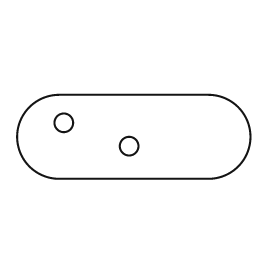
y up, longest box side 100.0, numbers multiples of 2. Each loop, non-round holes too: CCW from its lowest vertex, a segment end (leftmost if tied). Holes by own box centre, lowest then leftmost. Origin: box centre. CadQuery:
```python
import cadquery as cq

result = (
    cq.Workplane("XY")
    .moveTo(-32.0, -18.0)
    .lineTo(32.0, -18.0)
    .threePointArc((50.0, 0.0), (32.0, 18.0))
    .lineTo(-32.0, 18.0)
    .threePointArc((-50.0, 0.0), (-32.0, -18.0))
    .close()
    .moveTo(-2.0, -4.0)
    .circle(4.0)
    .moveTo(-30.0, 6.0)
    .circle(4.0)
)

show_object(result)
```